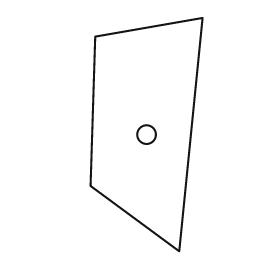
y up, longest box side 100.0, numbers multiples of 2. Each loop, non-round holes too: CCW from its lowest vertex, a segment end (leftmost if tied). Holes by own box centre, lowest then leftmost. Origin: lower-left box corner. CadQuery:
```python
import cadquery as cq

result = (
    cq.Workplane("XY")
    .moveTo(38.0, 0.0)
    .lineTo(48.0, 100.0)
    .lineTo(2.0, 92.0)
    .lineTo(0.0, 28.0)
    .close()
    .moveTo(24.0, 50.0)
    .circle(4.0)
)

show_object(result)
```